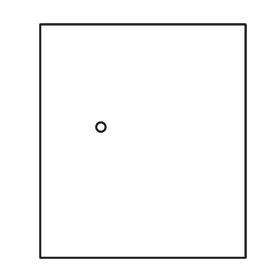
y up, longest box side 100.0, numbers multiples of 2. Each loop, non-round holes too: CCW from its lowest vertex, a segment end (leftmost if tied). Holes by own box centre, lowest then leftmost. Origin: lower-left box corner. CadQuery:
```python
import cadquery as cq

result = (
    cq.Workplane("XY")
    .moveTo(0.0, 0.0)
    .lineTo(88.0, 0.0)
    .lineTo(88.0, 100.0)
    .lineTo(0.0, 100.0)
    .close()
    .moveTo(26.0, 56.0)
    .circle(2.0)
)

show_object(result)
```